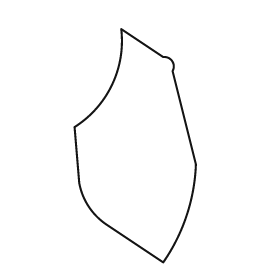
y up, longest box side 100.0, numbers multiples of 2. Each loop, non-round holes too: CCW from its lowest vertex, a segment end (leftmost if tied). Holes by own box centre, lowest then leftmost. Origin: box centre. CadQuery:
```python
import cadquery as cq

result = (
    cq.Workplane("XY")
    .moveTo(12.0, -50.0)
    .threePointArc((22.0, -30.0), (26.0, -8.0))
    .lineTo(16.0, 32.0)
    .threePointArc((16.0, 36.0), (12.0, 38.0))
    .lineTo(-6.0, 50.0)
    .threePointArc((-10.0, 26.0), (-26.0, 8.0))
    .lineTo(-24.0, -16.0)
    .threePointArc((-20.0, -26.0), (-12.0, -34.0))
    .close()
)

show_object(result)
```